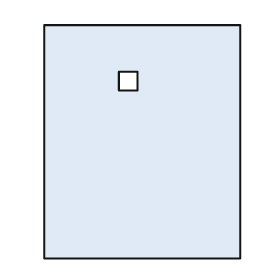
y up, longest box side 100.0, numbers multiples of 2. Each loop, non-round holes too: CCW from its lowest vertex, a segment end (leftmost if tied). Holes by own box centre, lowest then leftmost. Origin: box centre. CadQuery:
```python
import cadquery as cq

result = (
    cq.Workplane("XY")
    .moveTo(-42.0, -50.0)
    .lineTo(42.0, -50.0)
    .lineTo(42.0, 50.0)
    .lineTo(-42.0, 50.0)
    .close()
    .moveTo(-10.0, 22.0)
    .lineTo(-2.0, 22.0)
    .lineTo(-2.0, 30.0)
    .lineTo(-10.0, 30.0)
    .close()
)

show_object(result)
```